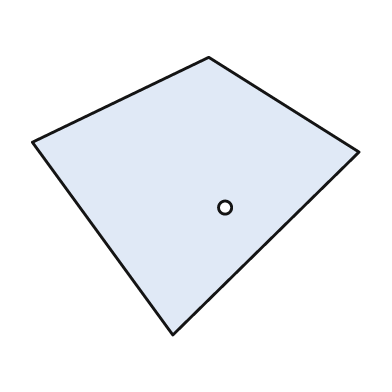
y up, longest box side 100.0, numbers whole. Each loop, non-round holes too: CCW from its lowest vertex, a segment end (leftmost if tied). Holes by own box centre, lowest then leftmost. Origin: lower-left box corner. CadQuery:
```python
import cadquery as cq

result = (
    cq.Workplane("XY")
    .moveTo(43.0, 0.0)
    .lineTo(100.0, 56.0)
    .lineTo(54.0, 85.0)
    .lineTo(0.0, 59.0)
    .close()
    .moveTo(59.0, 39.0)
    .circle(2.0)
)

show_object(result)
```